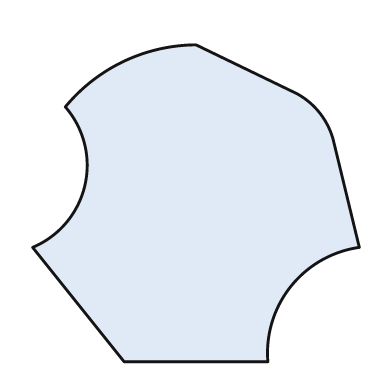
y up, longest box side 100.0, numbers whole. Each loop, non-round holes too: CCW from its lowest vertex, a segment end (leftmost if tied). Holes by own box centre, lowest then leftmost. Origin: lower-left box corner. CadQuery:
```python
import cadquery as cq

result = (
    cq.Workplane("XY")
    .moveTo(28.0, 0.0)
    .lineTo(72.0, 0.0)
    .threePointArc((79.0, 23.0), (100.0, 35.0))
    .lineTo(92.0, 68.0)
    .threePointArc((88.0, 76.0), (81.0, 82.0))
    .lineTo(50.0, 97.0)
    .threePointArc((28.0, 92.0), (10.0, 78.0))
    .threePointArc((16.0, 54.0), (0.0, 35.0))
    .close()
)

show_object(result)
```